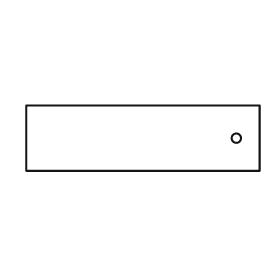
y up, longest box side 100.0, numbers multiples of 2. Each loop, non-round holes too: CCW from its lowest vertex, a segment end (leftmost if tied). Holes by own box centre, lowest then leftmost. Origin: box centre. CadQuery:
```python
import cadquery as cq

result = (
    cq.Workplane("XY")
    .moveTo(-50.0, -14.0)
    .lineTo(50.0, -14.0)
    .lineTo(50.0, 14.0)
    .lineTo(-50.0, 14.0)
    .close()
    .moveTo(40.0, 0.0)
    .circle(2.0)
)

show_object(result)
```